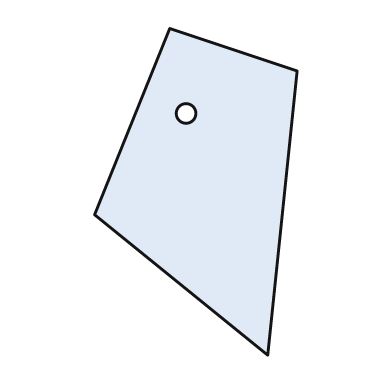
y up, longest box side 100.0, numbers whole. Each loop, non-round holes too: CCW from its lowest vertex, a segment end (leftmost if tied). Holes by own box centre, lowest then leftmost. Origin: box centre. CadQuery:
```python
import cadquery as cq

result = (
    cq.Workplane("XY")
    .moveTo(22.0, -50.0)
    .lineTo(31.0, 37.0)
    .lineTo(-8.0, 50.0)
    .lineTo(-31.0, -7.0)
    .close()
    .moveTo(-3.0, 24.0)
    .circle(3.0)
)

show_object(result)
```